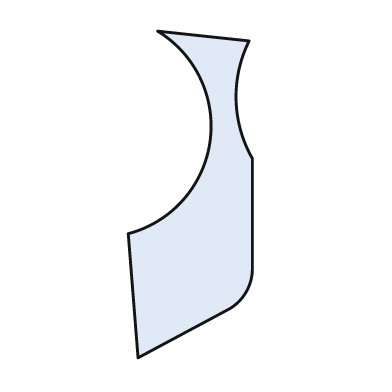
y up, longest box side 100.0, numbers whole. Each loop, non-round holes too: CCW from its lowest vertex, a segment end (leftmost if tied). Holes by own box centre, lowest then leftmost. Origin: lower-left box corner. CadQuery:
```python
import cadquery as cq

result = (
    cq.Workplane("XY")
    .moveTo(3.0, 0.0)
    .lineTo(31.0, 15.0)
    .threePointArc((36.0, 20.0), (38.0, 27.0))
    .lineTo(38.0, 61.0)
    .threePointArc((33.0, 79.0), (37.0, 97.0))
    .lineTo(9.0, 100.0)
    .threePointArc((25.0, 66.0), (0.0, 38.0))
    .close()
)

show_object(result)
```